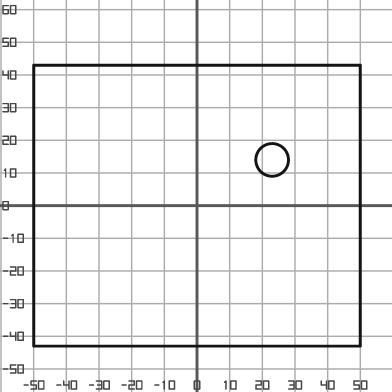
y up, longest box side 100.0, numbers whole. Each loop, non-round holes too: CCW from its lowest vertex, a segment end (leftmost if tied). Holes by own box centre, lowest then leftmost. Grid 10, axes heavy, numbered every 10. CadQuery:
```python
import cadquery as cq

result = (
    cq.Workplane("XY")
    .moveTo(-50.0, -43.0)
    .lineTo(50.0, -43.0)
    .lineTo(50.0, 43.0)
    .lineTo(-50.0, 43.0)
    .close()
    .moveTo(23.0, 14.0)
    .circle(5.0)
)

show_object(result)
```